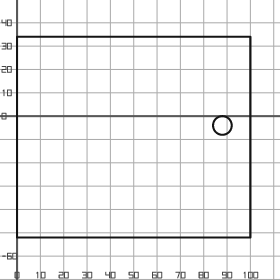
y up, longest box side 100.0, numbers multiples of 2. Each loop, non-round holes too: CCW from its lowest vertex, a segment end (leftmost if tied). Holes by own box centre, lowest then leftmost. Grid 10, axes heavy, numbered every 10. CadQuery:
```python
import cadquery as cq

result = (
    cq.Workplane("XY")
    .moveTo(0.0, -52.0)
    .lineTo(100.0, -52.0)
    .lineTo(100.0, 34.0)
    .lineTo(0.0, 34.0)
    .close()
    .moveTo(88.0, -4.0)
    .circle(4.0)
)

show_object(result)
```